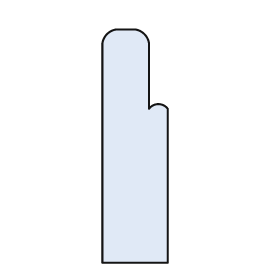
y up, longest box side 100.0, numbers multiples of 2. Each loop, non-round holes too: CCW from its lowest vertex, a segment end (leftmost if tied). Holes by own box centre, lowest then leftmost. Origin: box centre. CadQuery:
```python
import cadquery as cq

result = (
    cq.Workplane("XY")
    .moveTo(-14.0, -50.0)
    .lineTo(14.0, -50.0)
    .lineTo(14.0, 16.0)
    .threePointArc((10.0, 18.0), (6.0, 16.0))
    .lineTo(6.0, 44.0)
    .threePointArc((4.0, 48.0), (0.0, 50.0))
    .lineTo(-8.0, 50.0)
    .threePointArc((-12.0, 48.0), (-14.0, 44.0))
    .close()
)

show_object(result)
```